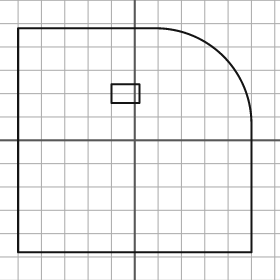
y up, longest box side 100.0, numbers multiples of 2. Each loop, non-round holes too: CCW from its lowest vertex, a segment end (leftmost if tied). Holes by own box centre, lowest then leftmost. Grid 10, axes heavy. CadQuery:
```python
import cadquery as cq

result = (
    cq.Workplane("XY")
    .moveTo(-50.0, -48.0)
    .lineTo(50.0, -48.0)
    .lineTo(50.0, 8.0)
    .threePointArc((38.0, 36.0), (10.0, 48.0))
    .lineTo(-50.0, 48.0)
    .close()
    .moveTo(-10.0, 16.0)
    .lineTo(2.0, 16.0)
    .lineTo(2.0, 24.0)
    .lineTo(-10.0, 24.0)
    .close()
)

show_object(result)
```